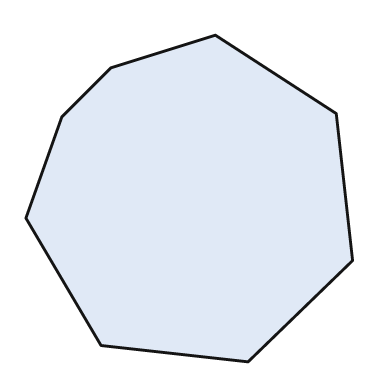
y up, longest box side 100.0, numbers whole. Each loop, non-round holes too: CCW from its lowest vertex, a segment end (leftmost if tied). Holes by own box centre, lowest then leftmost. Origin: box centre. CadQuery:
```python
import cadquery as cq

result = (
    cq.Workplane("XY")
    .moveTo(18.0, -50.0)
    .lineTo(50.0, -19.0)
    .lineTo(45.0, 26.0)
    .lineTo(8.0, 50.0)
    .lineTo(-24.0, 40.0)
    .lineTo(-39.0, 25.0)
    .lineTo(-50.0, -6.0)
    .lineTo(-27.0, -45.0)
    .close()
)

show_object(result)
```